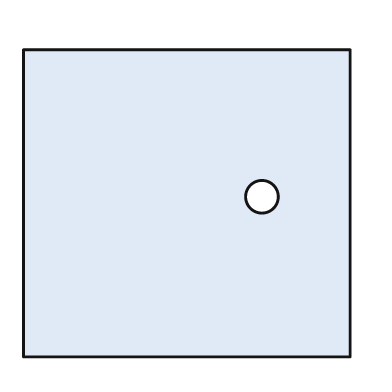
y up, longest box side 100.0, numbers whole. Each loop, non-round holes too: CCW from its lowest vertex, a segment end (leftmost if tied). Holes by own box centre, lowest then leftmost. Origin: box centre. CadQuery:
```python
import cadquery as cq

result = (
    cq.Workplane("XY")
    .moveTo(-50.0, -47.0)
    .lineTo(50.0, -47.0)
    .lineTo(50.0, 47.0)
    .lineTo(-50.0, 47.0)
    .close()
    .moveTo(23.0, 2.0)
    .circle(5.0)
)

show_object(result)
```